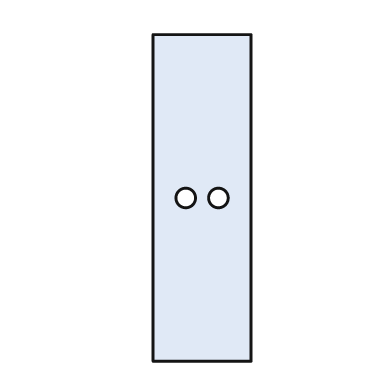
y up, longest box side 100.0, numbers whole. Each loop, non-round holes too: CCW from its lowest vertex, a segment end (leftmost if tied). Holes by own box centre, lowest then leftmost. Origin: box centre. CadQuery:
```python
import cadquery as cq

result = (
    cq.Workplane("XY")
    .moveTo(-15.0, -50.0)
    .lineTo(15.0, -50.0)
    .lineTo(15.0, 50.0)
    .lineTo(-15.0, 50.0)
    .close()
    .moveTo(-5.0, 0.0)
    .circle(3.0)
    .moveTo(5.0, 0.0)
    .circle(3.0)
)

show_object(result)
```